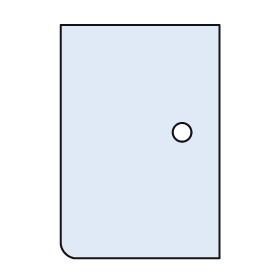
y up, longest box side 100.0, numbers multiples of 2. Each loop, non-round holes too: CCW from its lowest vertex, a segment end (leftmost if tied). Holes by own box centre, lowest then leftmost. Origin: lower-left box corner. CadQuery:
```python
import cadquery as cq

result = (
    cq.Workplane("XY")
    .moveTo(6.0, 0.0)
    .lineTo(68.0, 0.0)
    .lineTo(68.0, 100.0)
    .lineTo(0.0, 100.0)
    .lineTo(0.0, 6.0)
    .threePointArc((2.0, 2.0), (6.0, 0.0))
    .close()
    .moveTo(52.0, 54.0)
    .circle(4.0)
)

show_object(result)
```